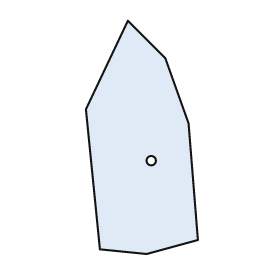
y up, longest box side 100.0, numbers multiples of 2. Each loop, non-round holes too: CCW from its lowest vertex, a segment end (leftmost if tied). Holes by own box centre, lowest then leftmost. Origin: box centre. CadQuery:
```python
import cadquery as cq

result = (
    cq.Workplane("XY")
    .moveTo(2.0, -50.0)
    .lineTo(24.0, -44.0)
    .lineTo(20.0, 6.0)
    .lineTo(10.0, 34.0)
    .lineTo(-6.0, 50.0)
    .lineTo(-24.0, 12.0)
    .lineTo(-18.0, -48.0)
    .close()
    .moveTo(4.0, -10.0)
    .circle(2.0)
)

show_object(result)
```